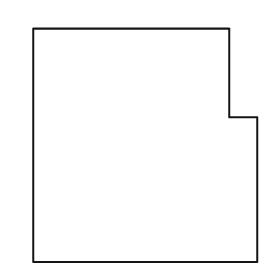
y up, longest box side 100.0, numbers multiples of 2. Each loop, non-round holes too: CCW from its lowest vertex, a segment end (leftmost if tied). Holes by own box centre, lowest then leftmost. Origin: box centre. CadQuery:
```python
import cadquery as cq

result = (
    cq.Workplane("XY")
    .moveTo(-48.0, -50.0)
    .lineTo(48.0, -50.0)
    .lineTo(48.0, 12.0)
    .lineTo(36.0, 12.0)
    .lineTo(36.0, 50.0)
    .lineTo(-48.0, 50.0)
    .close()
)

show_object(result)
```